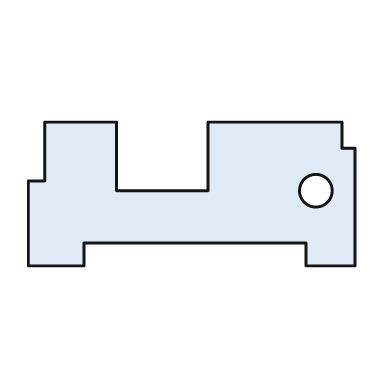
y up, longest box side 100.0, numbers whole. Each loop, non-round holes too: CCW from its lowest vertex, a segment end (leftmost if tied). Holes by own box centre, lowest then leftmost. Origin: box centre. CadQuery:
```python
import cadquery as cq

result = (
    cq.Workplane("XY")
    .moveTo(-50.0, -22.0)
    .lineTo(-33.0, -22.0)
    .lineTo(-33.0, -15.0)
    .lineTo(35.0, -15.0)
    .lineTo(35.0, -22.0)
    .lineTo(50.0, -22.0)
    .lineTo(50.0, 14.0)
    .lineTo(46.0, 14.0)
    .lineTo(46.0, 22.0)
    .lineTo(5.0, 22.0)
    .lineTo(5.0, 1.0)
    .lineTo(-23.0, 1.0)
    .lineTo(-23.0, 22.0)
    .lineTo(-45.0, 22.0)
    .lineTo(-45.0, 4.0)
    .lineTo(-50.0, 4.0)
    .close()
    .moveTo(38.0, 1.0)
    .circle(5.0)
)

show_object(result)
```